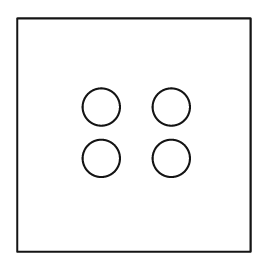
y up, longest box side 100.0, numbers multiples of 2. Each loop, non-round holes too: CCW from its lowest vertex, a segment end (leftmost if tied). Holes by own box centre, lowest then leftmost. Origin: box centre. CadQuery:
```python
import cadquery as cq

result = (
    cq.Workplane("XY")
    .moveTo(-50.0, -50.0)
    .lineTo(50.0, -50.0)
    .lineTo(50.0, 50.0)
    .lineTo(-50.0, 50.0)
    .close()
    .moveTo(-14.0, -10.0)
    .circle(8.0)
    .moveTo(16.0, -10.0)
    .circle(8.0)
    .moveTo(-14.0, 12.0)
    .circle(8.0)
    .moveTo(16.0, 12.0)
    .circle(8.0)
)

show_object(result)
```